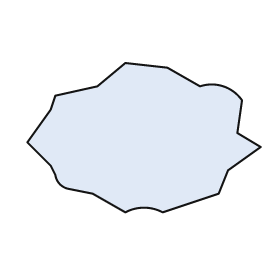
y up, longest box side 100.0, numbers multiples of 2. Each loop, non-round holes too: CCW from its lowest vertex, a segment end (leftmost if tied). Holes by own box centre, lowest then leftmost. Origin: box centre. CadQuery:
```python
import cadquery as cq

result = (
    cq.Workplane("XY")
    .moveTo(-8.0, -32.0)
    .threePointArc((0.0, -30.0), (8.0, -32.0))
    .lineTo(32.0, -24.0)
    .lineTo(36.0, -14.0)
    .lineTo(50.0, -4.0)
    .lineTo(40.0, 2.0)
    .lineTo(42.0, 16.0)
    .threePointArc((34.0, 22.0), (24.0, 22.0))
    .lineTo(10.0, 30.0)
    .lineTo(-8.0, 32.0)
    .lineTo(-20.0, 22.0)
    .lineTo(-38.0, 18.0)
    .lineTo(-40.0, 12.0)
    .lineTo(-50.0, -2.0)
    .lineTo(-40.0, -12.0)
    .lineTo(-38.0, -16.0)
    .threePointArc((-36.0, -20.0), (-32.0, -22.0))
    .lineTo(-22.0, -24.0)
    .close()
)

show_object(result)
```